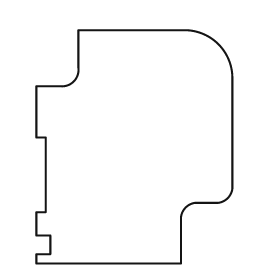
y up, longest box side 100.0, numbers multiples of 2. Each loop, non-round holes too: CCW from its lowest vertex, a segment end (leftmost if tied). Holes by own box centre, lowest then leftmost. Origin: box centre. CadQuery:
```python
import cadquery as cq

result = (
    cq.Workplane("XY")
    .moveTo(-42.0, -50.0)
    .lineTo(20.0, -50.0)
    .lineTo(20.0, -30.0)
    .threePointArc((22.0, -26.0), (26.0, -24.0))
    .lineTo(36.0, -24.0)
    .threePointArc((40.0, -22.0), (42.0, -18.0))
    .lineTo(42.0, 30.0)
    .threePointArc((36.0, 44.0), (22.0, 50.0))
    .lineTo(-24.0, 50.0)
    .lineTo(-24.0, 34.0)
    .threePointArc((-26.0, 28.0), (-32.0, 26.0))
    .lineTo(-42.0, 26.0)
    .lineTo(-42.0, 4.0)
    .lineTo(-38.0, 4.0)
    .lineTo(-38.0, -28.0)
    .lineTo(-42.0, -28.0)
    .lineTo(-42.0, -38.0)
    .lineTo(-36.0, -38.0)
    .lineTo(-36.0, -46.0)
    .lineTo(-42.0, -46.0)
    .close()
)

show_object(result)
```